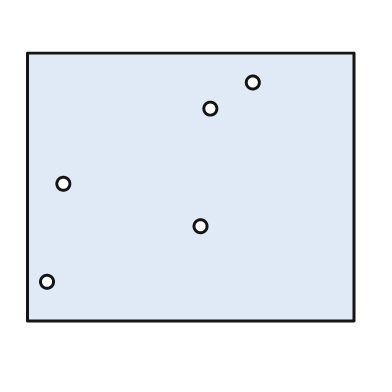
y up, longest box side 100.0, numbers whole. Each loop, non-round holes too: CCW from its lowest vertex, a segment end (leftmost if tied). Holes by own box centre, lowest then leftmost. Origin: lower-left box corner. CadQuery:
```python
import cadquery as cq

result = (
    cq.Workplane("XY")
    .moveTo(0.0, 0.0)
    .lineTo(100.0, 0.0)
    .lineTo(100.0, 82.0)
    .lineTo(0.0, 82.0)
    .close()
    .moveTo(6.0, 12.0)
    .circle(2.0)
    .moveTo(53.0, 29.0)
    .circle(2.0)
    .moveTo(11.0, 42.0)
    .circle(2.0)
    .moveTo(56.0, 65.0)
    .circle(2.0)
    .moveTo(69.0, 73.0)
    .circle(2.0)
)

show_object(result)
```